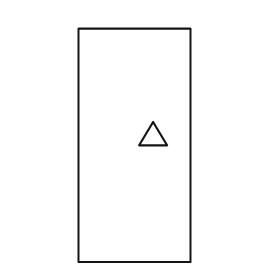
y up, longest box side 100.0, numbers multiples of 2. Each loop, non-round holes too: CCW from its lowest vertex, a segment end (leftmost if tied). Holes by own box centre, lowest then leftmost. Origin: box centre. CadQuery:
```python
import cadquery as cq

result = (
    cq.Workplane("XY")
    .moveTo(-24.0, -50.0)
    .lineTo(24.0, -50.0)
    .lineTo(24.0, 50.0)
    .lineTo(-24.0, 50.0)
    .close()
    .moveTo(2.0, 0.0)
    .lineTo(14.0, 0.0)
    .lineTo(8.0, 10.0)
    .close()
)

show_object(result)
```